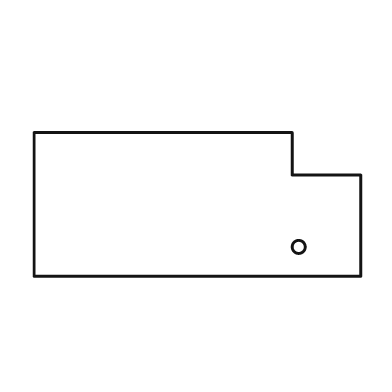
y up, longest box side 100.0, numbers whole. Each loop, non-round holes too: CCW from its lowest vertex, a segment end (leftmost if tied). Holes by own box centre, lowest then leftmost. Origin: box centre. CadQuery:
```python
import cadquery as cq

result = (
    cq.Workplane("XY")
    .moveTo(-50.0, -22.0)
    .lineTo(50.0, -22.0)
    .lineTo(50.0, 9.0)
    .lineTo(29.0, 9.0)
    .lineTo(29.0, 22.0)
    .lineTo(-50.0, 22.0)
    .close()
    .moveTo(31.0, -13.0)
    .circle(2.0)
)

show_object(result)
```